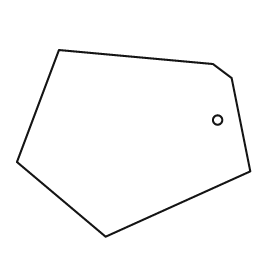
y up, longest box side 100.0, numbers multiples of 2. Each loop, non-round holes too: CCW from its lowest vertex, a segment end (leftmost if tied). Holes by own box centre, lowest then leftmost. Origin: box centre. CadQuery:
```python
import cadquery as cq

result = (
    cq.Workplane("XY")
    .moveTo(-12.0, -40.0)
    .lineTo(50.0, -12.0)
    .lineTo(42.0, 28.0)
    .lineTo(34.0, 34.0)
    .lineTo(-32.0, 40.0)
    .lineTo(-50.0, -8.0)
    .close()
    .moveTo(36.0, 10.0)
    .circle(2.0)
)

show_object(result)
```